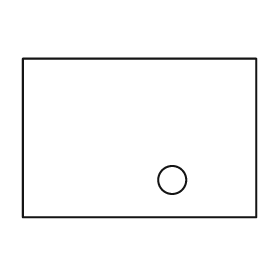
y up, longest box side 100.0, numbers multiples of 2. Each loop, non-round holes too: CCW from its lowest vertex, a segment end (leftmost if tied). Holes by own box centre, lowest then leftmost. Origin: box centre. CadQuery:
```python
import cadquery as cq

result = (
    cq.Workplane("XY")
    .moveTo(-50.0, -34.0)
    .lineTo(50.0, -34.0)
    .lineTo(50.0, 34.0)
    .lineTo(-50.0, 34.0)
    .close()
    .moveTo(14.0, -18.0)
    .circle(6.0)
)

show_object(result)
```